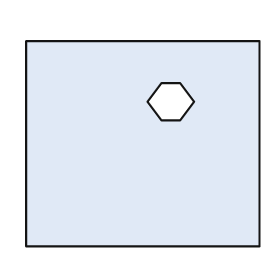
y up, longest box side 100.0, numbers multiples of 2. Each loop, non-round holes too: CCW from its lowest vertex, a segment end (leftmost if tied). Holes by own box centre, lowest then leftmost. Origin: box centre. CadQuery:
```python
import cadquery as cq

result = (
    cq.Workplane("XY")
    .moveTo(-50.0, -44.0)
    .lineTo(50.0, -44.0)
    .lineTo(50.0, 44.0)
    .lineTo(-50.0, 44.0)
    .close()
    .moveTo(8.0, 10.0)
    .lineTo(16.0, 10.0)
    .lineTo(22.0, 18.0)
    .lineTo(16.0, 26.0)
    .lineTo(8.0, 26.0)
    .lineTo(2.0, 18.0)
    .close()
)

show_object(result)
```